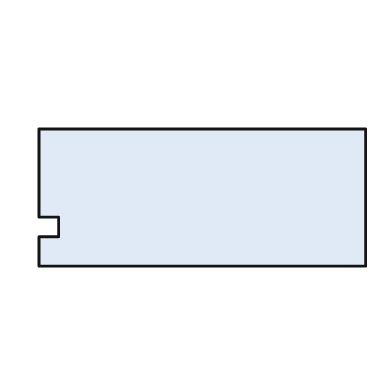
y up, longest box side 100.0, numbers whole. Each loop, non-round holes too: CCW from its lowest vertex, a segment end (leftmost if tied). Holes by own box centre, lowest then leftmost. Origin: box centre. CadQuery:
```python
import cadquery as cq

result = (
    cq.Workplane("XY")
    .moveTo(-50.0, -21.0)
    .lineTo(50.0, -21.0)
    .lineTo(50.0, 21.0)
    .lineTo(-50.0, 21.0)
    .lineTo(-50.0, -6.0)
    .lineTo(-44.0, -6.0)
    .lineTo(-44.0, -12.0)
    .lineTo(-50.0, -12.0)
    .close()
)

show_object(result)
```